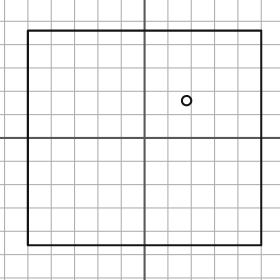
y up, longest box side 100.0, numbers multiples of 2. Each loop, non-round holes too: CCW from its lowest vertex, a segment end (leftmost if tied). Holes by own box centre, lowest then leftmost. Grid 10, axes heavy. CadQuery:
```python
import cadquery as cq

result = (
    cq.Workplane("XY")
    .moveTo(-50.0, -46.0)
    .lineTo(50.0, -46.0)
    .lineTo(50.0, 46.0)
    .lineTo(-50.0, 46.0)
    .close()
    .moveTo(18.0, 16.0)
    .circle(2.0)
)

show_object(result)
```